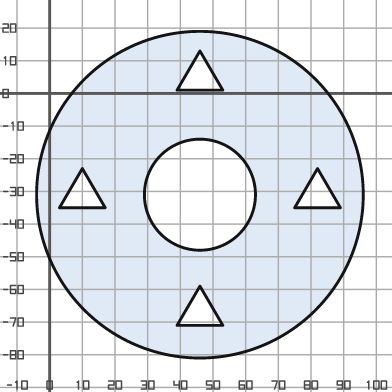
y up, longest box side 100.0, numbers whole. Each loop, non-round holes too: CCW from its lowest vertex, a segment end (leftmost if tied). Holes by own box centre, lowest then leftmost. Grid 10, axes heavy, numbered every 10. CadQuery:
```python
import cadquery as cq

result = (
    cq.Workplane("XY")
    .moveTo(46.0, -31.0)
    .circle(50.0)
    .moveTo(39.0, -71.0)
    .lineTo(53.0, -71.0)
    .lineTo(46.0, -59.0)
    .close()
    .moveTo(46.0, -31.0)
    .circle(17.0)
    .moveTo(3.0, -35.0)
    .lineTo(17.0, -35.0)
    .lineTo(10.0, -23.0)
    .close()
    .moveTo(75.0, -35.0)
    .lineTo(89.0, -35.0)
    .lineTo(82.0, -23.0)
    .close()
    .moveTo(39.0, 1.0)
    .lineTo(53.0, 1.0)
    .lineTo(46.0, 13.0)
    .close()
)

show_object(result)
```